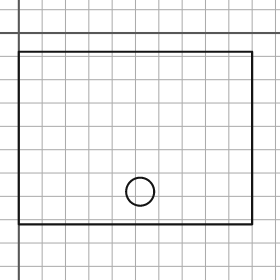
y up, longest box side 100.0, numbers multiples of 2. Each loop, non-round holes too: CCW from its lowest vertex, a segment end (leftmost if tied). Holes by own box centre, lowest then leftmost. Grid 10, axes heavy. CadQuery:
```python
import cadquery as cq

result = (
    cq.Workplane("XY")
    .moveTo(0.0, -82.0)
    .lineTo(100.0, -82.0)
    .lineTo(100.0, -8.0)
    .lineTo(0.0, -8.0)
    .close()
    .moveTo(52.0, -68.0)
    .circle(6.0)
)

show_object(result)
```